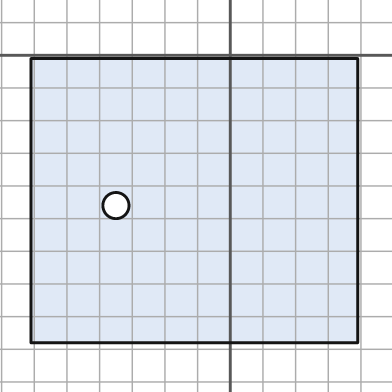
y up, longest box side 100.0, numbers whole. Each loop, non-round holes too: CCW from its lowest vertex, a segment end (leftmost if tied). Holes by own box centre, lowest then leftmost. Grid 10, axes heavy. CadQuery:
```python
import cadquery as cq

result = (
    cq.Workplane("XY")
    .moveTo(-61.0, -88.0)
    .lineTo(39.0, -88.0)
    .lineTo(39.0, -1.0)
    .lineTo(-61.0, -1.0)
    .close()
    .moveTo(-35.0, -46.0)
    .circle(4.0)
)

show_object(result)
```